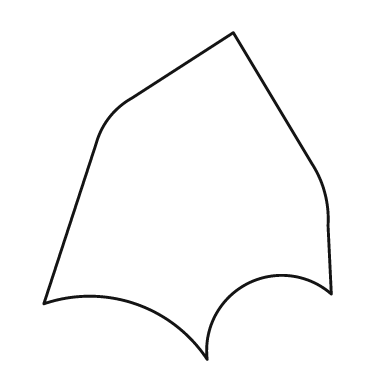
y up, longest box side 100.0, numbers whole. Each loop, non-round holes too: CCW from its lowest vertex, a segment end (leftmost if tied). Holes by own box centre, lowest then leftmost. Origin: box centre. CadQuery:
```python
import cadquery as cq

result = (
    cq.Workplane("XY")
    .moveTo(6.0, -50.0)
    .threePointArc((18.0, -27.0), (44.0, -30.0))
    .lineTo(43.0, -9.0)
    .threePointArc((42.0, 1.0), (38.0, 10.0))
    .lineTo(14.0, 50.0)
    .lineTo(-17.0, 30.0)
    .threePointArc((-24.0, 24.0), (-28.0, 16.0))
    .lineTo(-44.0, -33.0)
    .threePointArc((-16.0, -33.0), (6.0, -50.0))
    .close()
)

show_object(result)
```